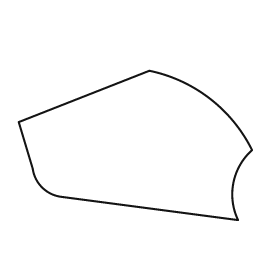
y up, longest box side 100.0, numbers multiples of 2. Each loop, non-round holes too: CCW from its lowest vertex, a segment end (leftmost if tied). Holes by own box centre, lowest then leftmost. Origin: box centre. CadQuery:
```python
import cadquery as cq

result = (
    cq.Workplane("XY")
    .moveTo(44.0, -32.0)
    .threePointArc((42.0, -16.0), (50.0, -2.0))
    .threePointArc((32.0, 20.0), (6.0, 32.0))
    .lineTo(-50.0, 10.0)
    .lineTo(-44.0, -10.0)
    .threePointArc((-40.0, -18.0), (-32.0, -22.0))
    .close()
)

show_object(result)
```